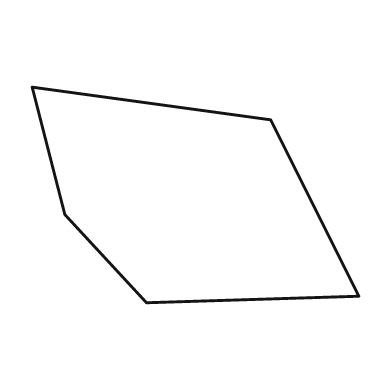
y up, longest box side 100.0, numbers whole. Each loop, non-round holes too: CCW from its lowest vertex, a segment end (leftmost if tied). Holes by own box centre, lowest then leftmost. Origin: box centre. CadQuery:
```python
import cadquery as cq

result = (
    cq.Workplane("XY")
    .moveTo(-15.0, -33.0)
    .lineTo(50.0, -31.0)
    .lineTo(23.0, 23.0)
    .lineTo(-50.0, 33.0)
    .lineTo(-40.0, -6.0)
    .close()
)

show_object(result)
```